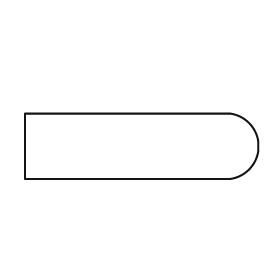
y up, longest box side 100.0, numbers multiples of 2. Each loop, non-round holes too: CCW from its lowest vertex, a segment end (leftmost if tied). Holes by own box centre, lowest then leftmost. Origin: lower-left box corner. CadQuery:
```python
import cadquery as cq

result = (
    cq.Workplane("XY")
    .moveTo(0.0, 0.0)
    .lineTo(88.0, 0.0)
    .threePointArc((96.0, 4.0), (100.0, 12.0))
    .lineTo(100.0, 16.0)
    .threePointArc((96.0, 24.0), (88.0, 28.0))
    .lineTo(0.0, 28.0)
    .close()
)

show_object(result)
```